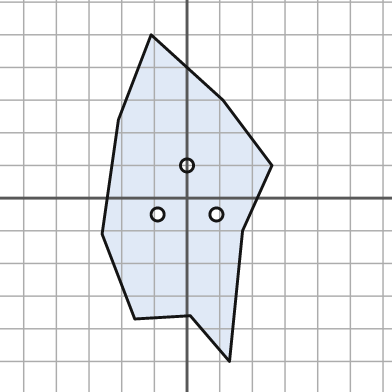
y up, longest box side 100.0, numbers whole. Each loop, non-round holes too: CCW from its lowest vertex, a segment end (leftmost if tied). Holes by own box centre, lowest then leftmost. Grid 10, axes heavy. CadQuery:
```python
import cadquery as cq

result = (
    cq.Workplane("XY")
    .moveTo(13.0, -50.0)
    .lineTo(17.0, -10.0)
    .lineTo(26.0, 10.0)
    .lineTo(11.0, 30.0)
    .lineTo(-11.0, 50.0)
    .lineTo(-21.0, 24.0)
    .lineTo(-26.0, -11.0)
    .lineTo(-16.0, -37.0)
    .lineTo(1.0, -36.0)
    .close()
    .moveTo(-9.0, -5.0)
    .circle(2.0)
    .moveTo(9.0, -5.0)
    .circle(2.0)
    .moveTo(0.0, 10.0)
    .circle(2.0)
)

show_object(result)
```